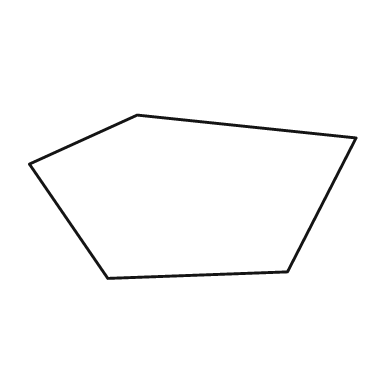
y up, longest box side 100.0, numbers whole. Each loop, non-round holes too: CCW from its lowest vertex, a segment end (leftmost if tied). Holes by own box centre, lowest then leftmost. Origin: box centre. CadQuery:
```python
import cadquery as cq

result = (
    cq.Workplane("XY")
    .moveTo(-26.0, -25.0)
    .lineTo(29.0, -23.0)
    .lineTo(50.0, 18.0)
    .lineTo(-17.0, 25.0)
    .lineTo(-50.0, 10.0)
    .close()
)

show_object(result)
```